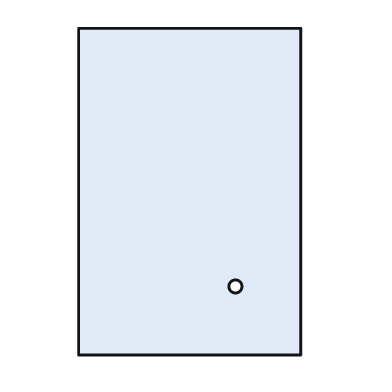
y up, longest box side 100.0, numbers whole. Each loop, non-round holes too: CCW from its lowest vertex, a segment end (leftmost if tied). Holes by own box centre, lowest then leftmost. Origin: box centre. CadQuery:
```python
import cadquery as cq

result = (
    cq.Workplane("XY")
    .moveTo(-34.0, -50.0)
    .lineTo(34.0, -50.0)
    .lineTo(34.0, 50.0)
    .lineTo(-34.0, 50.0)
    .close()
    .moveTo(14.0, -29.0)
    .circle(2.0)
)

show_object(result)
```